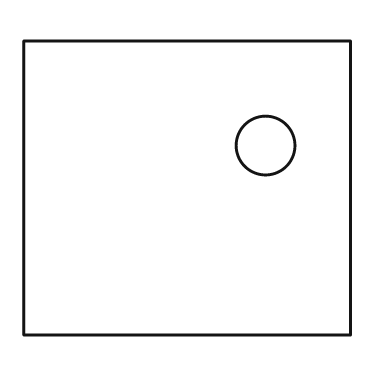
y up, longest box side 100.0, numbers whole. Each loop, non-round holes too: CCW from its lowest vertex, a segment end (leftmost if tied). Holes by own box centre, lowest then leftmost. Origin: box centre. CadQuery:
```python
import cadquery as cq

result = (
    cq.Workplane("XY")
    .moveTo(-50.0, -45.0)
    .lineTo(50.0, -45.0)
    .lineTo(50.0, 45.0)
    .lineTo(-50.0, 45.0)
    .close()
    .moveTo(24.0, 13.0)
    .circle(9.0)
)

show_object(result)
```